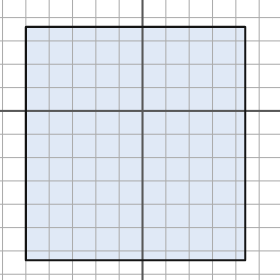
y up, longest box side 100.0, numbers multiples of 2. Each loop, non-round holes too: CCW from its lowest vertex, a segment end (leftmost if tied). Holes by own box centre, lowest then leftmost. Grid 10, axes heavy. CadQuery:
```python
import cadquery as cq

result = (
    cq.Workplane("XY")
    .moveTo(-50.0, -64.0)
    .lineTo(44.0, -64.0)
    .lineTo(44.0, 36.0)
    .lineTo(-50.0, 36.0)
    .close()
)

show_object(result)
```